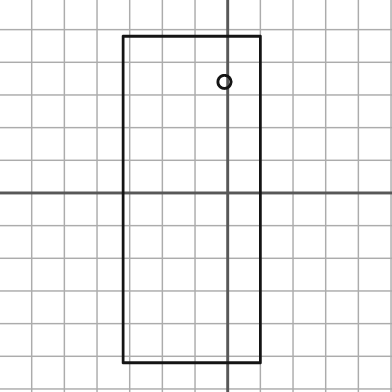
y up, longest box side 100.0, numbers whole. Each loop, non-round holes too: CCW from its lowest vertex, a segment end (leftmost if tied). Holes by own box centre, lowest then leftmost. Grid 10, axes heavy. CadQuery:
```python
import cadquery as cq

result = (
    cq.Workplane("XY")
    .moveTo(-32.0, -52.0)
    .lineTo(10.0, -52.0)
    .lineTo(10.0, 48.0)
    .lineTo(-32.0, 48.0)
    .close()
    .moveTo(-1.0, 34.0)
    .circle(2.0)
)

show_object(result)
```